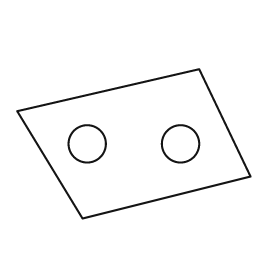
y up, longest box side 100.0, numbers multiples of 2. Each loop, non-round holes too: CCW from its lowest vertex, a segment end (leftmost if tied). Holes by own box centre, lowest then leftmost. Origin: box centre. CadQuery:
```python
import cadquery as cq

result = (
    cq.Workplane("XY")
    .moveTo(-22.0, -32.0)
    .lineTo(50.0, -14.0)
    .lineTo(28.0, 32.0)
    .lineTo(-50.0, 14.0)
    .close()
    .moveTo(-20.0, 0.0)
    .circle(8.0)
    .moveTo(20.0, 0.0)
    .circle(8.0)
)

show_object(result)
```